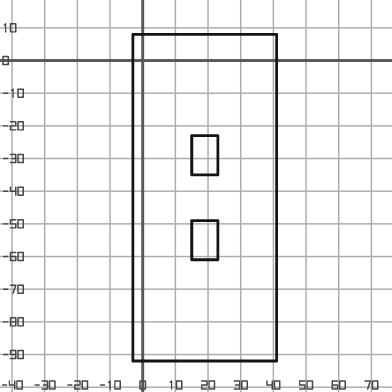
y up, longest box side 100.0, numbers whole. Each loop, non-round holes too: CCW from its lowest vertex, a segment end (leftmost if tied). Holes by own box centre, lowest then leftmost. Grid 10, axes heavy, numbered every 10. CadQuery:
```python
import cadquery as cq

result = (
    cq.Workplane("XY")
    .moveTo(-3.0, -92.0)
    .lineTo(41.0, -92.0)
    .lineTo(41.0, 8.0)
    .lineTo(-3.0, 8.0)
    .close()
    .moveTo(15.0, -61.0)
    .lineTo(23.0, -61.0)
    .lineTo(23.0, -49.0)
    .lineTo(15.0, -49.0)
    .close()
    .moveTo(15.0, -35.0)
    .lineTo(23.0, -35.0)
    .lineTo(23.0, -23.0)
    .lineTo(15.0, -23.0)
    .close()
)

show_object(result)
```